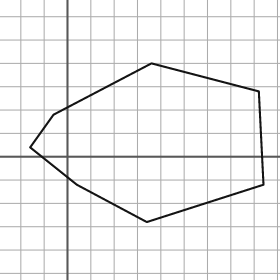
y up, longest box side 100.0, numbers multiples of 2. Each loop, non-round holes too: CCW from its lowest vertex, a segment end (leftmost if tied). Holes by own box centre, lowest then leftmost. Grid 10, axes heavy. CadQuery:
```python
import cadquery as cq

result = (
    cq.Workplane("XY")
    .moveTo(34.0, -28.0)
    .lineTo(84.0, -12.0)
    .lineTo(82.0, 28.0)
    .lineTo(36.0, 40.0)
    .lineTo(-6.0, 18.0)
    .lineTo(-16.0, 4.0)
    .lineTo(4.0, -12.0)
    .close()
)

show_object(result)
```